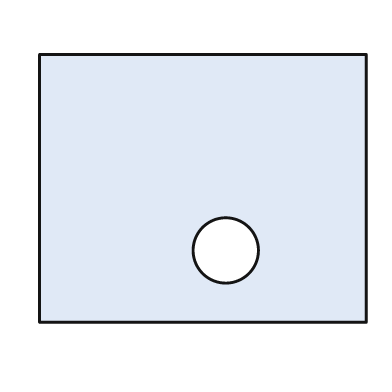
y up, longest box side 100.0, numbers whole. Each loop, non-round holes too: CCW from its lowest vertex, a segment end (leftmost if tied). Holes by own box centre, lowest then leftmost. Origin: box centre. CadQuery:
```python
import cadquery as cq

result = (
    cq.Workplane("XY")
    .moveTo(-50.0, -41.0)
    .lineTo(50.0, -41.0)
    .lineTo(50.0, 41.0)
    .lineTo(-50.0, 41.0)
    .close()
    .moveTo(7.0, -19.0)
    .circle(10.0)
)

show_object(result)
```